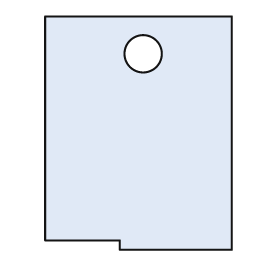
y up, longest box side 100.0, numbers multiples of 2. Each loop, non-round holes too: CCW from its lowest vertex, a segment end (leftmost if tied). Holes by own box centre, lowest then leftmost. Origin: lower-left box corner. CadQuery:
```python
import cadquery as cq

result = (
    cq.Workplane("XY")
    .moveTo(32.0, 0.0)
    .lineTo(80.0, 0.0)
    .lineTo(80.0, 100.0)
    .lineTo(0.0, 100.0)
    .lineTo(0.0, 4.0)
    .lineTo(32.0, 4.0)
    .close()
    .moveTo(42.0, 84.0)
    .circle(8.0)
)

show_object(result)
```